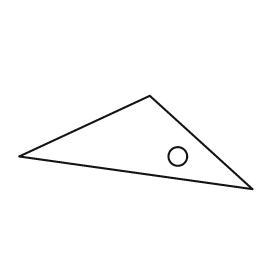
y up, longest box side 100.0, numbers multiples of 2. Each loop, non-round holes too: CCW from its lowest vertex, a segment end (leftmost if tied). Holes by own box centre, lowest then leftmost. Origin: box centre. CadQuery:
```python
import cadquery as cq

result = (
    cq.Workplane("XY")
    .moveTo(50.0, -20.0)
    .lineTo(6.0, 20.0)
    .lineTo(-50.0, -6.0)
    .close()
    .moveTo(18.0, -6.0)
    .circle(4.0)
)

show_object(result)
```